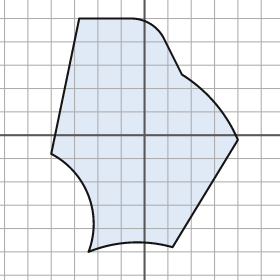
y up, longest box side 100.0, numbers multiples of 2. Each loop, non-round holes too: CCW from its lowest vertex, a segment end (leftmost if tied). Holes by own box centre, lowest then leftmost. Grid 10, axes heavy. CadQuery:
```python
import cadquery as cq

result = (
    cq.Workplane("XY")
    .moveTo(-24.0, -50.0)
    .threePointArc((-6.0, -46.0), (12.0, -48.0))
    .lineTo(40.0, -2.0)
    .threePointArc((30.0, 14.0), (16.0, 26.0))
    .lineTo(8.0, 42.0)
    .threePointArc((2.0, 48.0), (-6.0, 50.0))
    .lineTo(-28.0, 50.0)
    .lineTo(-40.0, -8.0)
    .threePointArc((-24.0, -26.0), (-24.0, -50.0))
    .close()
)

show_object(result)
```